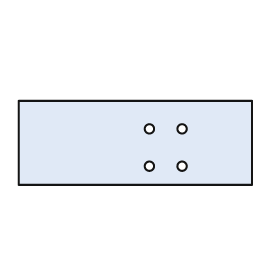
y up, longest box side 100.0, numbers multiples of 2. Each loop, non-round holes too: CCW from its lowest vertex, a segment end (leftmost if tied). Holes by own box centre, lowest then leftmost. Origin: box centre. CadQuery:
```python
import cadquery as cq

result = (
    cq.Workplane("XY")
    .moveTo(-50.0, -18.0)
    .lineTo(50.0, -18.0)
    .lineTo(50.0, 18.0)
    .lineTo(-50.0, 18.0)
    .close()
    .moveTo(6.0, -10.0)
    .circle(2.0)
    .moveTo(20.0, -10.0)
    .circle(2.0)
    .moveTo(6.0, 6.0)
    .circle(2.0)
    .moveTo(20.0, 6.0)
    .circle(2.0)
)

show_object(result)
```